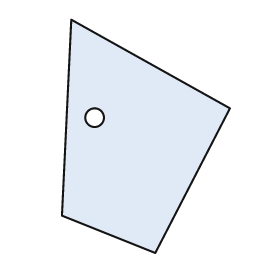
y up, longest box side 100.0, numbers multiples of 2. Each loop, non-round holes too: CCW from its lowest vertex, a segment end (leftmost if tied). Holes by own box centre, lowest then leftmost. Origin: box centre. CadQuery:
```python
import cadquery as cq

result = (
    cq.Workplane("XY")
    .moveTo(4.0, -50.0)
    .lineTo(36.0, 12.0)
    .lineTo(-32.0, 50.0)
    .lineTo(-36.0, -34.0)
    .close()
    .moveTo(-22.0, 8.0)
    .circle(4.0)
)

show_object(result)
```